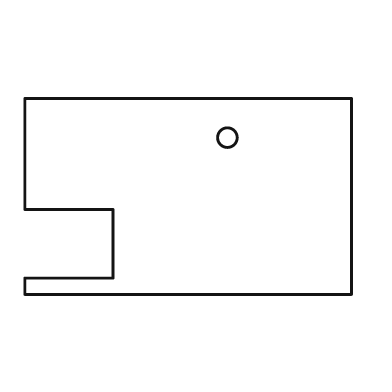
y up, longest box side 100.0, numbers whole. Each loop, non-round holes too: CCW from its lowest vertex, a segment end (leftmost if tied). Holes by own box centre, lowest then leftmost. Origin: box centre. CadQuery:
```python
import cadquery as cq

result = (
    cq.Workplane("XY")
    .moveTo(-50.0, -30.0)
    .lineTo(50.0, -30.0)
    .lineTo(50.0, 30.0)
    .lineTo(-50.0, 30.0)
    .lineTo(-50.0, -4.0)
    .lineTo(-23.0, -4.0)
    .lineTo(-23.0, -25.0)
    .lineTo(-50.0, -25.0)
    .close()
    .moveTo(12.0, 18.0)
    .circle(3.0)
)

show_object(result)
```